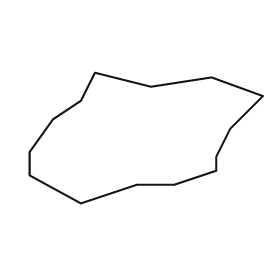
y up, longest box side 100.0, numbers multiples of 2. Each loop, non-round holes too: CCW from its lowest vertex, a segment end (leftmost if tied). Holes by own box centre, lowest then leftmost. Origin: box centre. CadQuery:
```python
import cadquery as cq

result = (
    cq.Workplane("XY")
    .moveTo(-28.0, -28.0)
    .lineTo(-4.0, -20.0)
    .lineTo(12.0, -20.0)
    .lineTo(30.0, -14.0)
    .lineTo(30.0, -8.0)
    .lineTo(36.0, 4.0)
    .lineTo(50.0, 18.0)
    .lineTo(28.0, 26.0)
    .lineTo(2.0, 22.0)
    .lineTo(-22.0, 28.0)
    .lineTo(-28.0, 16.0)
    .lineTo(-40.0, 8.0)
    .lineTo(-50.0, -6.0)
    .lineTo(-50.0, -16.0)
    .close()
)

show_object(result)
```